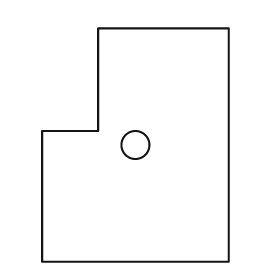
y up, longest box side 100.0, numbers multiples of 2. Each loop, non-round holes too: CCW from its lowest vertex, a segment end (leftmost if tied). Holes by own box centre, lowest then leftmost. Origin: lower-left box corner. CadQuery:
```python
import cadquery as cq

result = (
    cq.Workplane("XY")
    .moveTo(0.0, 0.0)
    .lineTo(80.0, 0.0)
    .lineTo(80.0, 100.0)
    .lineTo(24.0, 100.0)
    .lineTo(24.0, 56.0)
    .lineTo(0.0, 56.0)
    .close()
    .moveTo(40.0, 50.0)
    .circle(6.0)
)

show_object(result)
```